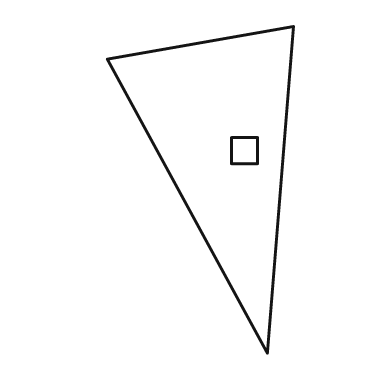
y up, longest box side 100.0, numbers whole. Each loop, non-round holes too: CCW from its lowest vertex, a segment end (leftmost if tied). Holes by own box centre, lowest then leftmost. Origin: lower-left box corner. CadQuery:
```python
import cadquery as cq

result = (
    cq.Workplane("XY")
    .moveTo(49.0, 0.0)
    .lineTo(57.0, 100.0)
    .lineTo(0.0, 90.0)
    .close()
    .moveTo(38.0, 58.0)
    .lineTo(46.0, 58.0)
    .lineTo(46.0, 66.0)
    .lineTo(38.0, 66.0)
    .close()
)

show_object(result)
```